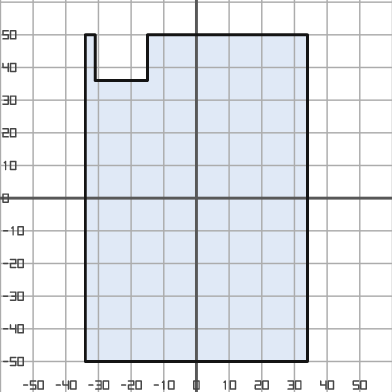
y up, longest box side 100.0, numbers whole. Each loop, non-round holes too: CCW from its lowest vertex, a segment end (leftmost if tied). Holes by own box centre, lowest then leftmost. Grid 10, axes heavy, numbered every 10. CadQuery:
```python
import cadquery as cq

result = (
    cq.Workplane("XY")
    .moveTo(-34.0, -50.0)
    .lineTo(34.0, -50.0)
    .lineTo(34.0, 50.0)
    .lineTo(-15.0, 50.0)
    .lineTo(-15.0, 36.0)
    .lineTo(-31.0, 36.0)
    .lineTo(-31.0, 50.0)
    .lineTo(-34.0, 50.0)
    .close()
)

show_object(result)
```